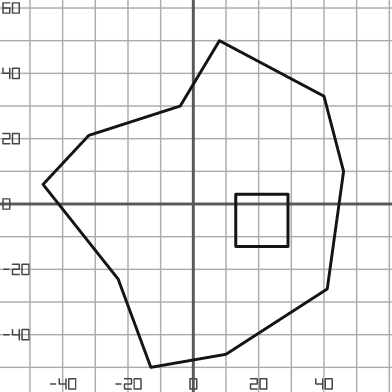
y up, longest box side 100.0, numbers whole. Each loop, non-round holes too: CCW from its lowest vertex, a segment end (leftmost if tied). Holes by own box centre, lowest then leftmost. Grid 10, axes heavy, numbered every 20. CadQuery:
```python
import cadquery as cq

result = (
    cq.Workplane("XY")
    .moveTo(-13.0, -50.0)
    .lineTo(10.0, -46.0)
    .lineTo(41.0, -26.0)
    .lineTo(46.0, 10.0)
    .lineTo(40.0, 33.0)
    .lineTo(8.0, 50.0)
    .lineTo(-4.0, 30.0)
    .lineTo(-32.0, 21.0)
    .lineTo(-46.0, 6.0)
    .lineTo(-23.0, -23.0)
    .close()
    .moveTo(13.0, -13.0)
    .lineTo(29.0, -13.0)
    .lineTo(29.0, 3.0)
    .lineTo(13.0, 3.0)
    .close()
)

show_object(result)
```